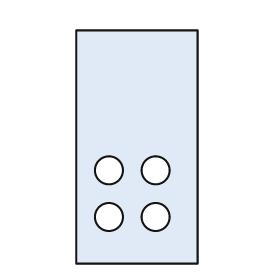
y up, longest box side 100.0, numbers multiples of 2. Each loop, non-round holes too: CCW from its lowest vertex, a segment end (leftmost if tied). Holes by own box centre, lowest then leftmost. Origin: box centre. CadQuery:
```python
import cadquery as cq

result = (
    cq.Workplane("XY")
    .moveTo(-26.0, -50.0)
    .lineTo(26.0, -50.0)
    .lineTo(26.0, 50.0)
    .lineTo(-26.0, 50.0)
    .close()
    .moveTo(-12.0, -30.0)
    .circle(6.0)
    .moveTo(8.0, -30.0)
    .circle(6.0)
    .moveTo(-12.0, -10.0)
    .circle(6.0)
    .moveTo(8.0, -10.0)
    .circle(6.0)
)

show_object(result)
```